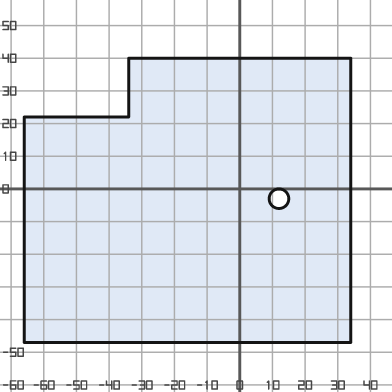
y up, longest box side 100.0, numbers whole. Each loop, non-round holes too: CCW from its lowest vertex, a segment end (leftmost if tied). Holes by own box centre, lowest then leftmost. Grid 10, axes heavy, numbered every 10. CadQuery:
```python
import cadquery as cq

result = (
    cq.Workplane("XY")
    .moveTo(-66.0, -47.0)
    .lineTo(34.0, -47.0)
    .lineTo(34.0, 40.0)
    .lineTo(-34.0, 40.0)
    .lineTo(-34.0, 22.0)
    .lineTo(-66.0, 22.0)
    .close()
    .moveTo(12.0, -3.0)
    .circle(3.0)
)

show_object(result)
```